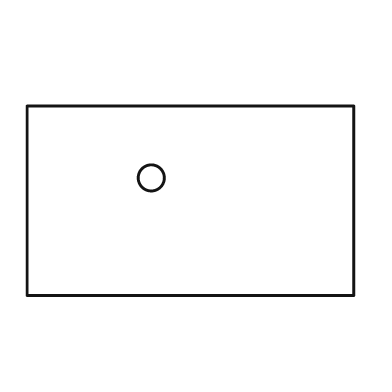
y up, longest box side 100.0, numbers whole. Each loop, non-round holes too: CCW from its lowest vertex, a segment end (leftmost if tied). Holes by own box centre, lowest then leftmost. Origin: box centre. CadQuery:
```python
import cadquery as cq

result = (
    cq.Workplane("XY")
    .moveTo(-50.0, -29.0)
    .lineTo(50.0, -29.0)
    .lineTo(50.0, 29.0)
    .lineTo(-50.0, 29.0)
    .close()
    .moveTo(-12.0, 7.0)
    .circle(4.0)
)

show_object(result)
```